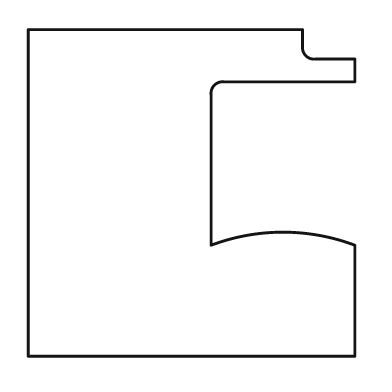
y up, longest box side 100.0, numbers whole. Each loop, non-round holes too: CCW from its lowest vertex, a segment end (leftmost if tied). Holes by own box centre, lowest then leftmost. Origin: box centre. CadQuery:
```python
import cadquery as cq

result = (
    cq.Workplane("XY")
    .moveTo(-50.0, -50.0)
    .lineTo(50.0, -50.0)
    .lineTo(50.0, -16.0)
    .threePointArc((28.0, -12.0), (6.0, -16.0))
    .lineTo(6.0, 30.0)
    .threePointArc((7.0, 33.0), (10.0, 34.0))
    .lineTo(50.0, 34.0)
    .lineTo(50.0, 41.0)
    .lineTo(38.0, 41.0)
    .threePointArc((35.0, 42.0), (34.0, 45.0))
    .lineTo(34.0, 50.0)
    .lineTo(-50.0, 50.0)
    .close()
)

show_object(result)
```